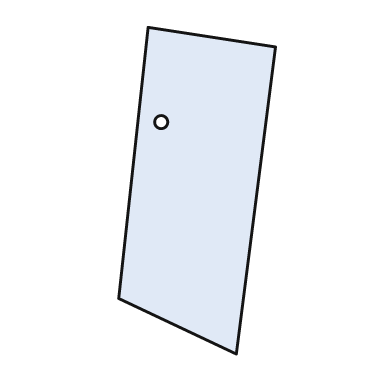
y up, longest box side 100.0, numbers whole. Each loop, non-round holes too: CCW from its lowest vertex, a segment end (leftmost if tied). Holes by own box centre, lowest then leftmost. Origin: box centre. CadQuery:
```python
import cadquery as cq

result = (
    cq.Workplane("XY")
    .moveTo(12.0, -50.0)
    .lineTo(24.0, 44.0)
    .lineTo(-15.0, 50.0)
    .lineTo(-24.0, -33.0)
    .close()
    .moveTo(-11.0, 21.0)
    .circle(2.0)
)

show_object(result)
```